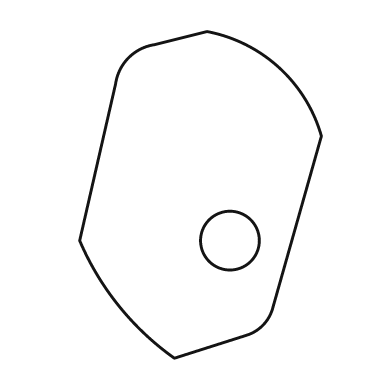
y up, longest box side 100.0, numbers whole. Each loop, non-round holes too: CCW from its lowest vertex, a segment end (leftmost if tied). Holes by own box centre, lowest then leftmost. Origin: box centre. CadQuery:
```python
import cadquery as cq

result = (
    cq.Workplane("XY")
    .moveTo(-8.0, -50.0)
    .lineTo(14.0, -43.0)
    .threePointArc((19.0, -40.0), (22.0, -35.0))
    .lineTo(37.0, 18.0)
    .threePointArc((24.0, 39.0), (2.0, 50.0))
    .lineTo(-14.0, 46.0)
    .threePointArc((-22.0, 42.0), (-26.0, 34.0))
    .lineTo(-37.0, -14.0)
    .threePointArc((-25.0, -34.0), (-8.0, -50.0))
    .close()
    .moveTo(9.0, -14.0)
    .circle(9.0)
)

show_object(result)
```